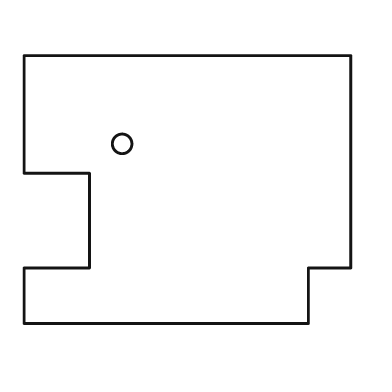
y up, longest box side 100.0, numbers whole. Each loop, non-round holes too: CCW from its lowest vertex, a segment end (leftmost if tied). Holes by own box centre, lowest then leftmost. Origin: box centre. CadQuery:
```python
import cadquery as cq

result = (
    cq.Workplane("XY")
    .moveTo(-50.0, -41.0)
    .lineTo(37.0, -41.0)
    .lineTo(37.0, -24.0)
    .lineTo(50.0, -24.0)
    .lineTo(50.0, 41.0)
    .lineTo(-50.0, 41.0)
    .lineTo(-50.0, 5.0)
    .lineTo(-30.0, 5.0)
    .lineTo(-30.0, -24.0)
    .lineTo(-50.0, -24.0)
    .close()
    .moveTo(-20.0, 14.0)
    .circle(3.0)
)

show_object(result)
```